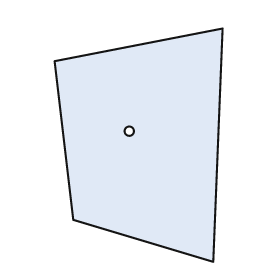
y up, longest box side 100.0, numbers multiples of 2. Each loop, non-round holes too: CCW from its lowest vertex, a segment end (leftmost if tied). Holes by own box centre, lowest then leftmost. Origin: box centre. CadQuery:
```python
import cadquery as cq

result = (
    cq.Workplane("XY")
    .moveTo(32.0, -50.0)
    .lineTo(36.0, 50.0)
    .lineTo(-36.0, 36.0)
    .lineTo(-28.0, -32.0)
    .close()
    .moveTo(-4.0, 6.0)
    .circle(2.0)
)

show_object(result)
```